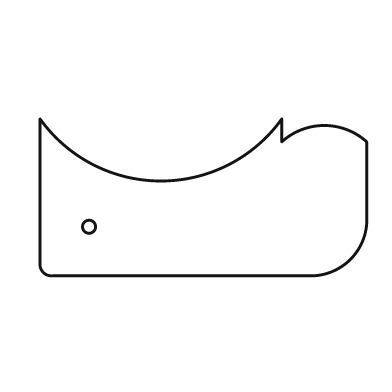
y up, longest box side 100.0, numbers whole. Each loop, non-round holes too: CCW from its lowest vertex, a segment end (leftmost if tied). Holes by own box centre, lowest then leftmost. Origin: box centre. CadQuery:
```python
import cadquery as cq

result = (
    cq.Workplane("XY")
    .moveTo(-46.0, -24.0)
    .lineTo(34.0, -24.0)
    .threePointArc((45.0, -19.0), (50.0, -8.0))
    .lineTo(50.0, 17.0)
    .threePointArc((37.0, 22.0), (24.0, 17.0))
    .lineTo(24.0, 24.0)
    .threePointArc((-13.0, 5.0), (-50.0, 24.0))
    .lineTo(-50.0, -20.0)
    .threePointArc((-49.0, -23.0), (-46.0, -24.0))
    .close()
    .moveTo(-35.0, -9.0)
    .circle(2.0)
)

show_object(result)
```